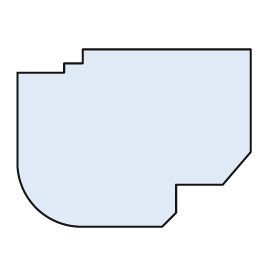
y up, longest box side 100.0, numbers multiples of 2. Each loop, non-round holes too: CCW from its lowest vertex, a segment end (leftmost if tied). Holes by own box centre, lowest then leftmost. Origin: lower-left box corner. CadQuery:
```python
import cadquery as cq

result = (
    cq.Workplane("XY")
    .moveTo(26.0, 0.0)
    .lineTo(62.0, 0.0)
    .lineTo(68.0, 6.0)
    .lineTo(68.0, 18.0)
    .lineTo(88.0, 18.0)
    .lineTo(100.0, 32.0)
    .lineTo(100.0, 76.0)
    .lineTo(28.0, 76.0)
    .lineTo(28.0, 70.0)
    .lineTo(20.0, 70.0)
    .lineTo(20.0, 66.0)
    .lineTo(0.0, 66.0)
    .lineTo(0.0, 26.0)
    .threePointArc((8.0, 8.0), (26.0, 0.0))
    .close()
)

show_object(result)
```